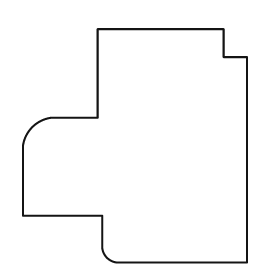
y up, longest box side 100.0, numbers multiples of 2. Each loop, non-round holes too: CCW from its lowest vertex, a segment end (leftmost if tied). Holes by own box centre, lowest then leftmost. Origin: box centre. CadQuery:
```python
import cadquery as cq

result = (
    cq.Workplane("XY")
    .moveTo(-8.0, -50.0)
    .lineTo(48.0, -50.0)
    .lineTo(48.0, 38.0)
    .lineTo(38.0, 38.0)
    .lineTo(38.0, 50.0)
    .lineTo(-16.0, 50.0)
    .lineTo(-16.0, 12.0)
    .lineTo(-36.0, 12.0)
    .threePointArc((-44.0, 8.0), (-48.0, 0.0))
    .lineTo(-48.0, -30.0)
    .lineTo(-14.0, -30.0)
    .lineTo(-14.0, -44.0)
    .threePointArc((-12.0, -48.0), (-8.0, -50.0))
    .close()
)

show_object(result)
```